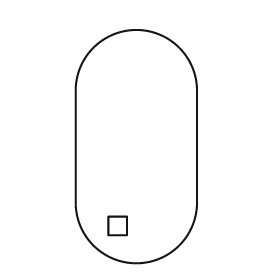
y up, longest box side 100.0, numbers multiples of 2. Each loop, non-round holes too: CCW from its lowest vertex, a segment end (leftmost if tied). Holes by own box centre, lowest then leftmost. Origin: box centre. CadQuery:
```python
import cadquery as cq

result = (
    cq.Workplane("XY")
    .moveTo(-26.0, -24.0)
    .threePointArc((0.0, -50.0), (26.0, -24.0))
    .lineTo(26.0, 24.0)
    .threePointArc((0.0, 50.0), (-26.0, 24.0))
    .close()
    .moveTo(-12.0, -38.0)
    .lineTo(-4.0, -38.0)
    .lineTo(-4.0, -30.0)
    .lineTo(-12.0, -30.0)
    .close()
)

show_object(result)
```